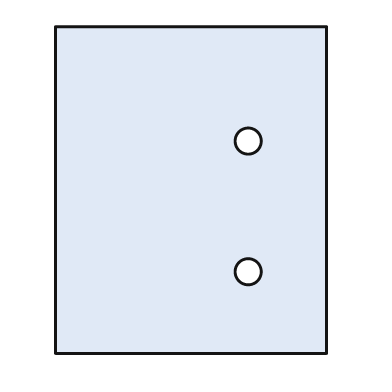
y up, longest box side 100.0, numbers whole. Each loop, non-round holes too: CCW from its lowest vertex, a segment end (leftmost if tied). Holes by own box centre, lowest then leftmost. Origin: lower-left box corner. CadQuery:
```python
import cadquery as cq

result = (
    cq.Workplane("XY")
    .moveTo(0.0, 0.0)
    .lineTo(83.0, 0.0)
    .lineTo(83.0, 100.0)
    .lineTo(0.0, 100.0)
    .close()
    .moveTo(59.0, 25.0)
    .circle(4.0)
    .moveTo(59.0, 65.0)
    .circle(4.0)
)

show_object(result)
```